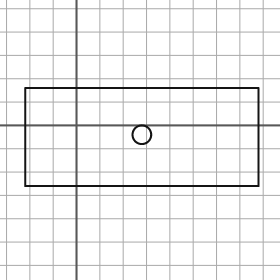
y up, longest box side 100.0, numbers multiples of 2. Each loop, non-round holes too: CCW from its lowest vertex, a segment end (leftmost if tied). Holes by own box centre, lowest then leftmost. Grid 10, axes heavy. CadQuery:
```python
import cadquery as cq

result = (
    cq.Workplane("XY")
    .moveTo(-22.0, -26.0)
    .lineTo(78.0, -26.0)
    .lineTo(78.0, 16.0)
    .lineTo(-22.0, 16.0)
    .close()
    .moveTo(28.0, -4.0)
    .circle(4.0)
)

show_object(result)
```